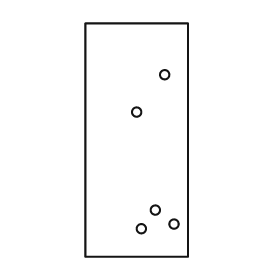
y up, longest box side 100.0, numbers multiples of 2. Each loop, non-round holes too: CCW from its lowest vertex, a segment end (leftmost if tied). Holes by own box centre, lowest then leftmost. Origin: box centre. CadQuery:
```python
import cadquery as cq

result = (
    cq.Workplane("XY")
    .moveTo(-22.0, -50.0)
    .lineTo(22.0, -50.0)
    .lineTo(22.0, 50.0)
    .lineTo(-22.0, 50.0)
    .close()
    .moveTo(2.0, -38.0)
    .circle(2.0)
    .moveTo(16.0, -36.0)
    .circle(2.0)
    .moveTo(8.0, -30.0)
    .circle(2.0)
    .moveTo(0.0, 12.0)
    .circle(2.0)
    .moveTo(12.0, 28.0)
    .circle(2.0)
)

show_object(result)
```